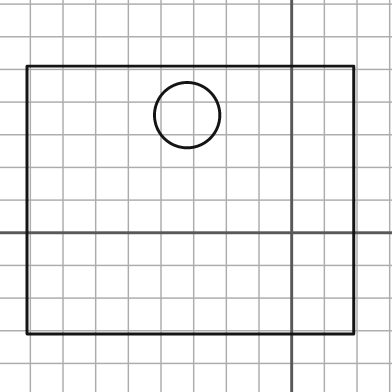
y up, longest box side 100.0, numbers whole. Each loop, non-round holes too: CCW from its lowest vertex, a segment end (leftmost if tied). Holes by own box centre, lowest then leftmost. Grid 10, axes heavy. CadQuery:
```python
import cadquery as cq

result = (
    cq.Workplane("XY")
    .moveTo(-81.0, -31.0)
    .lineTo(19.0, -31.0)
    .lineTo(19.0, 51.0)
    .lineTo(-81.0, 51.0)
    .close()
    .moveTo(-32.0, 36.0)
    .circle(10.0)
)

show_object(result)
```